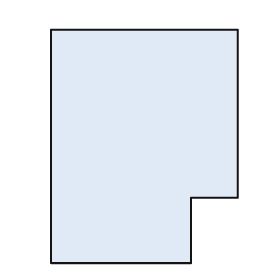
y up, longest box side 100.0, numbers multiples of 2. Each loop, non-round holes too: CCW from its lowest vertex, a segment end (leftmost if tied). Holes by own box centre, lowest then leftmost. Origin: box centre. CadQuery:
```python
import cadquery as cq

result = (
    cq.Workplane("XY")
    .moveTo(-40.0, -50.0)
    .lineTo(20.0, -50.0)
    .lineTo(20.0, -22.0)
    .lineTo(40.0, -22.0)
    .lineTo(40.0, 50.0)
    .lineTo(-40.0, 50.0)
    .close()
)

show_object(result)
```